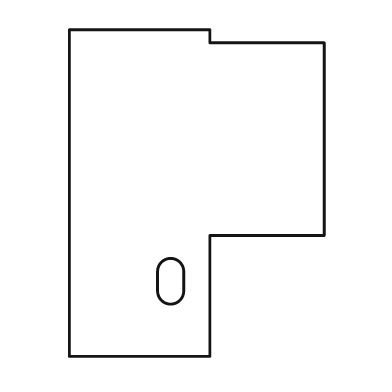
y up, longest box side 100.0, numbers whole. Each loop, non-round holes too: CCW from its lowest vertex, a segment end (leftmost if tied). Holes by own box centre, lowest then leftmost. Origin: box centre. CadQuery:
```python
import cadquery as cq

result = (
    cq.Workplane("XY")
    .moveTo(-39.0, -50.0)
    .lineTo(4.0, -50.0)
    .lineTo(4.0, -13.0)
    .lineTo(39.0, -13.0)
    .lineTo(39.0, 46.0)
    .lineTo(4.0, 46.0)
    .lineTo(4.0, 50.0)
    .lineTo(-39.0, 50.0)
    .close()
    .moveTo(-12.0, -30.0)
    .threePointArc((-8.0, -34.0), (-4.0, -30.0))
    .lineTo(-4.0, -24.0)
    .threePointArc((-8.0, -20.0), (-12.0, -24.0))
    .close()
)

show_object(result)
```